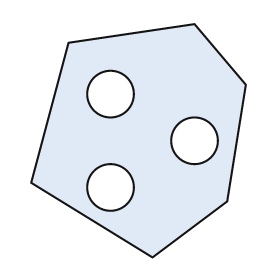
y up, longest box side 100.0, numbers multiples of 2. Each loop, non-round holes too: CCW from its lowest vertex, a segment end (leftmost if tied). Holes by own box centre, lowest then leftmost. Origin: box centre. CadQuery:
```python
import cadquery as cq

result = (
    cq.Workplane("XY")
    .moveTo(6.0, -50.0)
    .lineTo(38.0, -26.0)
    .lineTo(46.0, 24.0)
    .lineTo(24.0, 50.0)
    .lineTo(-30.0, 42.0)
    .lineTo(-46.0, -18.0)
    .close()
    .moveTo(-12.0, -20.0)
    .circle(10.0)
    .moveTo(24.0, 0.0)
    .circle(10.0)
    .moveTo(-12.0, 20.0)
    .circle(10.0)
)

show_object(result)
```